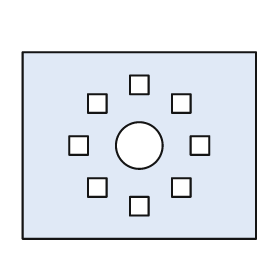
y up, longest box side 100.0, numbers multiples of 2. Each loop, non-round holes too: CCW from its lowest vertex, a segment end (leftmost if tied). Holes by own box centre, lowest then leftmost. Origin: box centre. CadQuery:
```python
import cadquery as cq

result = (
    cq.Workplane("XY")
    .moveTo(-50.0, -40.0)
    .lineTo(50.0, -40.0)
    .lineTo(50.0, 40.0)
    .lineTo(-50.0, 40.0)
    .close()
    .moveTo(-4.0, -30.0)
    .lineTo(4.0, -30.0)
    .lineTo(4.0, -22.0)
    .lineTo(-4.0, -22.0)
    .close()
    .moveTo(-22.0, -22.0)
    .lineTo(-14.0, -22.0)
    .lineTo(-14.0, -14.0)
    .lineTo(-22.0, -14.0)
    .close()
    .moveTo(14.0, -22.0)
    .lineTo(22.0, -22.0)
    .lineTo(22.0, -14.0)
    .lineTo(14.0, -14.0)
    .close()
    .moveTo(-30.0, -4.0)
    .lineTo(-22.0, -4.0)
    .lineTo(-22.0, 4.0)
    .lineTo(-30.0, 4.0)
    .close()
    .moveTo(0.0, 0.0)
    .circle(10.0)
    .moveTo(22.0, -4.0)
    .lineTo(30.0, -4.0)
    .lineTo(30.0, 4.0)
    .lineTo(22.0, 4.0)
    .close()
    .moveTo(-22.0, 14.0)
    .lineTo(-14.0, 14.0)
    .lineTo(-14.0, 22.0)
    .lineTo(-22.0, 22.0)
    .close()
    .moveTo(14.0, 14.0)
    .lineTo(22.0, 14.0)
    .lineTo(22.0, 22.0)
    .lineTo(14.0, 22.0)
    .close()
    .moveTo(-4.0, 22.0)
    .lineTo(4.0, 22.0)
    .lineTo(4.0, 30.0)
    .lineTo(-4.0, 30.0)
    .close()
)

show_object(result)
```